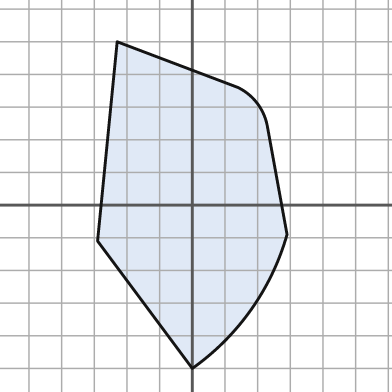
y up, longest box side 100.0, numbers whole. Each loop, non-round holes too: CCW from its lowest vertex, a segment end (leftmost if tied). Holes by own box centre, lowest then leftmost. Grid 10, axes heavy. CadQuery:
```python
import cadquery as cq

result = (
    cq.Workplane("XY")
    .moveTo(0.0, -50.0)
    .threePointArc((18.0, -32.0), (29.0, -9.0))
    .lineTo(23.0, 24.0)
    .threePointArc((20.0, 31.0), (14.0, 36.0))
    .lineTo(-23.0, 50.0)
    .lineTo(-29.0, -11.0)
    .close()
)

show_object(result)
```